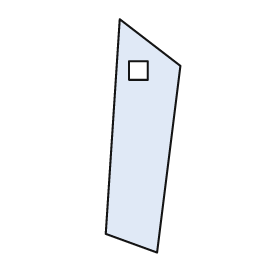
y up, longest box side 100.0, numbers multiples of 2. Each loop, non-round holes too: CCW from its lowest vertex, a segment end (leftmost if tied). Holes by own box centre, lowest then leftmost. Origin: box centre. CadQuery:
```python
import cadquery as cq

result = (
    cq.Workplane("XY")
    .moveTo(6.0, -50.0)
    .lineTo(16.0, 30.0)
    .lineTo(-10.0, 50.0)
    .lineTo(-16.0, -42.0)
    .close()
    .moveTo(-6.0, 24.0)
    .lineTo(2.0, 24.0)
    .lineTo(2.0, 32.0)
    .lineTo(-6.0, 32.0)
    .close()
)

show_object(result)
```